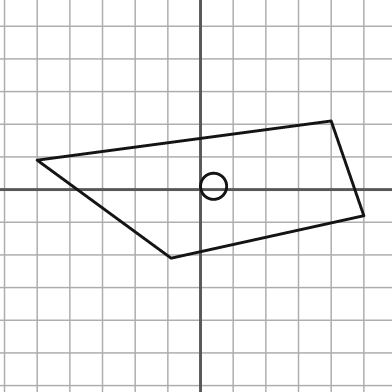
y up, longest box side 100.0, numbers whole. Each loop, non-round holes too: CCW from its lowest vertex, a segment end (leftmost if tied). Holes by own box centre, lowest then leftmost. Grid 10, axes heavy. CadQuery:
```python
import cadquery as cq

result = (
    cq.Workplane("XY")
    .moveTo(-9.0, -21.0)
    .lineTo(50.0, -8.0)
    .lineTo(40.0, 21.0)
    .lineTo(-50.0, 9.0)
    .close()
    .moveTo(4.0, 1.0)
    .circle(4.0)
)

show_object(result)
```